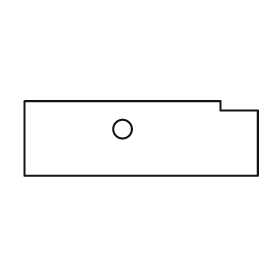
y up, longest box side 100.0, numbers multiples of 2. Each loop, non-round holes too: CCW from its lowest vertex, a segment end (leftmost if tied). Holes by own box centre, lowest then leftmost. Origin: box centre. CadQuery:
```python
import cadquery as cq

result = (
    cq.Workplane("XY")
    .moveTo(-50.0, -16.0)
    .lineTo(50.0, -16.0)
    .lineTo(50.0, 12.0)
    .lineTo(34.0, 12.0)
    .lineTo(34.0, 16.0)
    .lineTo(-50.0, 16.0)
    .close()
    .moveTo(-8.0, 4.0)
    .circle(4.0)
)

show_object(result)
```